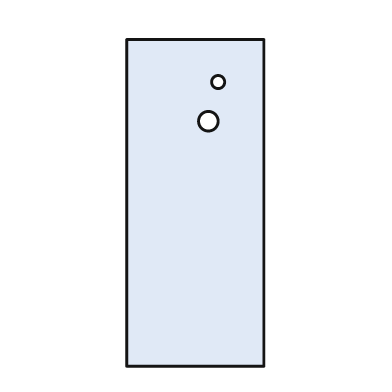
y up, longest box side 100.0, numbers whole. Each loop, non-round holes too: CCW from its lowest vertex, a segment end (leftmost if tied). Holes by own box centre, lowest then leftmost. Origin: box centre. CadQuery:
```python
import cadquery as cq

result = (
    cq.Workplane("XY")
    .moveTo(-21.0, -50.0)
    .lineTo(21.0, -50.0)
    .lineTo(21.0, 50.0)
    .lineTo(-21.0, 50.0)
    .close()
    .moveTo(4.0, 25.0)
    .circle(3.0)
    .moveTo(7.0, 37.0)
    .circle(2.0)
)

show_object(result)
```